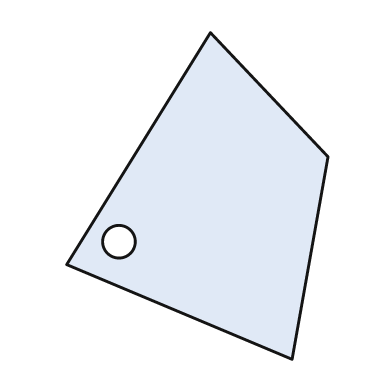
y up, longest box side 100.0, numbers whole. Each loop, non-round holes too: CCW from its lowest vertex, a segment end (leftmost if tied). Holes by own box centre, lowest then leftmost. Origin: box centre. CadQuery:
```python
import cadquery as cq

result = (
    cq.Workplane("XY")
    .moveTo(29.0, -50.0)
    .lineTo(40.0, 12.0)
    .lineTo(4.0, 50.0)
    .lineTo(-40.0, -21.0)
    .close()
    .moveTo(-24.0, -14.0)
    .circle(5.0)
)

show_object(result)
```